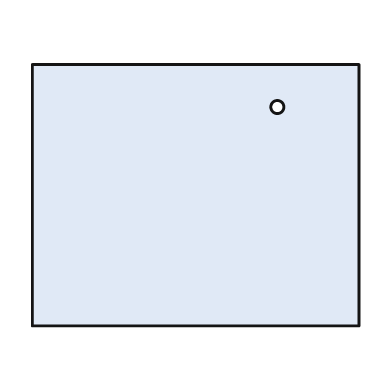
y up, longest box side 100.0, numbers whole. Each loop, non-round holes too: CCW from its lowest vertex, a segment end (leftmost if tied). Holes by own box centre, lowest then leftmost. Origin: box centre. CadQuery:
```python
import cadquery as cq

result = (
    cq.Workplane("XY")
    .moveTo(-50.0, -40.0)
    .lineTo(50.0, -40.0)
    .lineTo(50.0, 40.0)
    .lineTo(-50.0, 40.0)
    .close()
    .moveTo(25.0, 27.0)
    .circle(2.0)
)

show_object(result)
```